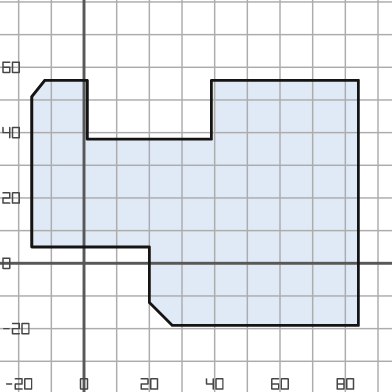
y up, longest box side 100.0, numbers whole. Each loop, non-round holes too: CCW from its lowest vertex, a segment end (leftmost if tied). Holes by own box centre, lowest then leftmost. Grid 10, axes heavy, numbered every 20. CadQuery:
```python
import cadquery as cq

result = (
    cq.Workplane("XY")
    .moveTo(27.0, -19.0)
    .lineTo(84.0, -19.0)
    .lineTo(84.0, 56.0)
    .lineTo(39.0, 56.0)
    .lineTo(39.0, 38.0)
    .lineTo(1.0, 38.0)
    .lineTo(1.0, 56.0)
    .lineTo(-12.0, 56.0)
    .lineTo(-16.0, 51.0)
    .lineTo(-16.0, 5.0)
    .lineTo(20.0, 5.0)
    .lineTo(20.0, -12.0)
    .close()
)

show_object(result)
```